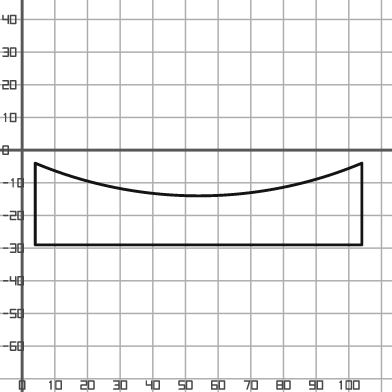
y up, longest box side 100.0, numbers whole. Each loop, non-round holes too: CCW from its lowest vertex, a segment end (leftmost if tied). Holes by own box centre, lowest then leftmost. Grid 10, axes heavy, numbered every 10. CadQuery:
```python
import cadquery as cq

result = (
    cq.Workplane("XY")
    .moveTo(4.0, -29.0)
    .lineTo(104.0, -29.0)
    .lineTo(104.0, -4.0)
    .threePointArc((54.0, -14.0), (4.0, -4.0))
    .close()
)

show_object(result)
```